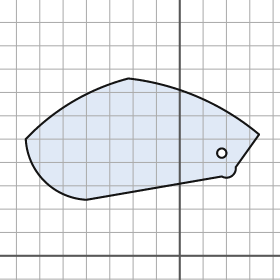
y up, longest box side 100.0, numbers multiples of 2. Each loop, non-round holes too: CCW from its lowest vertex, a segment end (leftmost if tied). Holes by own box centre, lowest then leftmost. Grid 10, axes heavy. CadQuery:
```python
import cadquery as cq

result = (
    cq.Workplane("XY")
    .moveTo(-40.0, 24.0)
    .lineTo(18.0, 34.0)
    .threePointArc((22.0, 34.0), (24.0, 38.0))
    .lineTo(34.0, 52.0)
    .threePointArc((8.0, 68.0), (-22.0, 76.0))
    .threePointArc((-46.0, 66.0), (-66.0, 50.0))
    .threePointArc((-58.0, 32.0), (-40.0, 24.0))
    .close()
    .moveTo(18.0, 44.0)
    .circle(2.0)
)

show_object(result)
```